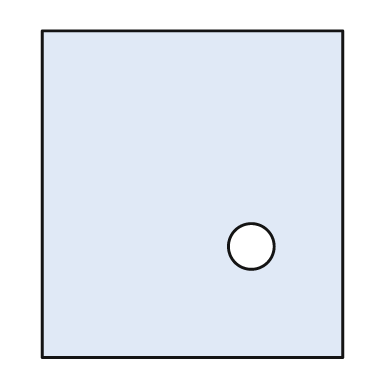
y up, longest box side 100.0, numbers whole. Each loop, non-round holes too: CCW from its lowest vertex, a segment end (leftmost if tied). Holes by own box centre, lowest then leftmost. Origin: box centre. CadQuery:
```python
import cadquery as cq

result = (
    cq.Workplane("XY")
    .moveTo(-46.0, -50.0)
    .lineTo(46.0, -50.0)
    .lineTo(46.0, 50.0)
    .lineTo(-46.0, 50.0)
    .close()
    .moveTo(18.0, -16.0)
    .circle(7.0)
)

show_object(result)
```